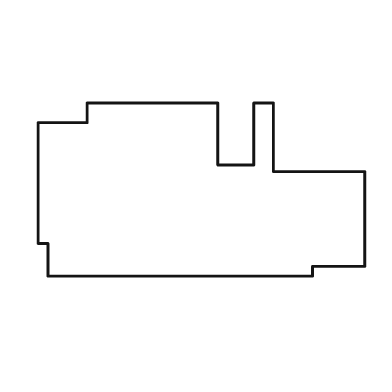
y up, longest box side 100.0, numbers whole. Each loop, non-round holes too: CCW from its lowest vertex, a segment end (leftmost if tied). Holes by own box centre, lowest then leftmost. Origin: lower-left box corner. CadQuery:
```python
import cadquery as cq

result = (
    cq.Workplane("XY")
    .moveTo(3.0, 0.0)
    .lineTo(84.0, 0.0)
    .lineTo(84.0, 3.0)
    .lineTo(100.0, 3.0)
    .lineTo(100.0, 32.0)
    .lineTo(72.0, 32.0)
    .lineTo(72.0, 53.0)
    .lineTo(66.0, 53.0)
    .lineTo(66.0, 34.0)
    .lineTo(55.0, 34.0)
    .lineTo(55.0, 53.0)
    .lineTo(15.0, 53.0)
    .lineTo(15.0, 47.0)
    .lineTo(0.0, 47.0)
    .lineTo(0.0, 10.0)
    .lineTo(3.0, 10.0)
    .close()
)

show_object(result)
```